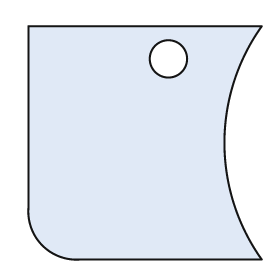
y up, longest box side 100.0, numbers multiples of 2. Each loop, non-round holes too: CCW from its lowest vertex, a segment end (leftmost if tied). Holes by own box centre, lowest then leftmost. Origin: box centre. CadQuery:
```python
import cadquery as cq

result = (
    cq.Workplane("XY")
    .moveTo(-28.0, -50.0)
    .lineTo(50.0, -50.0)
    .threePointArc((34.0, 0.0), (50.0, 50.0))
    .lineTo(-50.0, 50.0)
    .lineTo(-50.0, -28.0)
    .threePointArc((-44.0, -44.0), (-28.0, -50.0))
    .close()
    .moveTo(10.0, 36.0)
    .circle(8.0)
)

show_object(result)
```